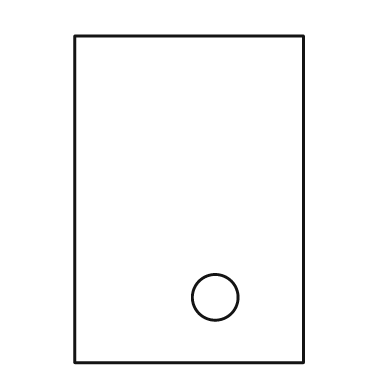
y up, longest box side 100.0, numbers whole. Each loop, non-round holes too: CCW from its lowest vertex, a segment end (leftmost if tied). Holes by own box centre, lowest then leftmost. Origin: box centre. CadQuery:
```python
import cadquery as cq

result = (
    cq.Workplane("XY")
    .moveTo(-35.0, -50.0)
    .lineTo(35.0, -50.0)
    .lineTo(35.0, 50.0)
    .lineTo(-35.0, 50.0)
    .close()
    .moveTo(8.0, -30.0)
    .circle(7.0)
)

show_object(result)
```